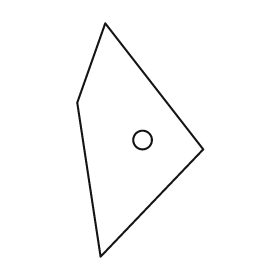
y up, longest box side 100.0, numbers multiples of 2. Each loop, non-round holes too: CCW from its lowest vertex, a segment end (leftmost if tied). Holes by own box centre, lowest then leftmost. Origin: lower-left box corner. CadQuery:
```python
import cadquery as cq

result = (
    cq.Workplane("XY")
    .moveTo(10.0, 0.0)
    .lineTo(54.0, 46.0)
    .lineTo(12.0, 100.0)
    .lineTo(0.0, 66.0)
    .close()
    .moveTo(28.0, 50.0)
    .circle(4.0)
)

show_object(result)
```